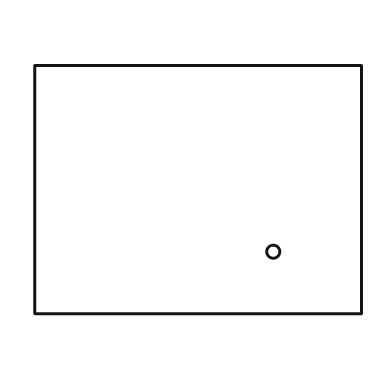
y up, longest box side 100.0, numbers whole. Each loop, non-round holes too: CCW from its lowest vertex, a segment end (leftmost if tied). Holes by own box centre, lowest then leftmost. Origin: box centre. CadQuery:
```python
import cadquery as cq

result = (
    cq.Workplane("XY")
    .moveTo(-50.0, -38.0)
    .lineTo(50.0, -38.0)
    .lineTo(50.0, 38.0)
    .lineTo(-50.0, 38.0)
    .close()
    .moveTo(23.0, -19.0)
    .circle(2.0)
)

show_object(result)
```